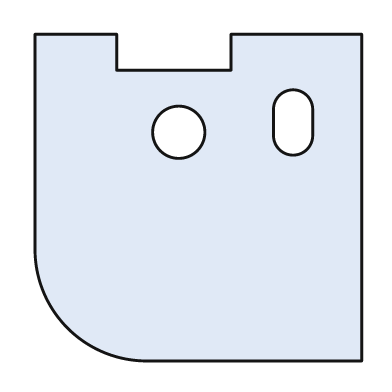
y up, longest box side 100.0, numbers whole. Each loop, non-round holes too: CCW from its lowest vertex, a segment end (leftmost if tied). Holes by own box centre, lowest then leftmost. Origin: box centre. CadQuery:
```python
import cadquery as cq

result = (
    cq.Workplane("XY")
    .moveTo(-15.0, -50.0)
    .lineTo(50.0, -50.0)
    .lineTo(50.0, 50.0)
    .lineTo(10.0, 50.0)
    .lineTo(10.0, 39.0)
    .lineTo(-25.0, 39.0)
    .lineTo(-25.0, 50.0)
    .lineTo(-50.0, 50.0)
    .lineTo(-50.0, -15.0)
    .threePointArc((-40.0, -40.0), (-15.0, -50.0))
    .close()
    .moveTo(-6.0, 20.0)
    .circle(8.0)
    .moveTo(23.0, 19.0)
    .threePointArc((29.0, 13.0), (35.0, 19.0))
    .lineTo(35.0, 27.0)
    .threePointArc((29.0, 33.0), (23.0, 27.0))
    .close()
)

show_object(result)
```